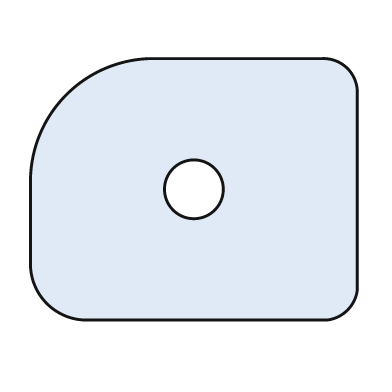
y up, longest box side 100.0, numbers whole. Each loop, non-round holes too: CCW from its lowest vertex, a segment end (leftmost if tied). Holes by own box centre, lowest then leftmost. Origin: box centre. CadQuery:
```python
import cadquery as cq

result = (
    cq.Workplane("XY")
    .moveTo(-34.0, -40.0)
    .lineTo(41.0, -40.0)
    .threePointArc((47.0, -37.0), (50.0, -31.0))
    .lineTo(50.0, 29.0)
    .threePointArc((47.0, 37.0), (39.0, 40.0))
    .lineTo(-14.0, 40.0)
    .threePointArc((-39.0, 29.0), (-50.0, 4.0))
    .lineTo(-50.0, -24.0)
    .threePointArc((-45.0, -35.0), (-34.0, -40.0))
    .close()
    .moveTo(0.0, 0.0)
    .circle(9.0)
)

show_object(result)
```